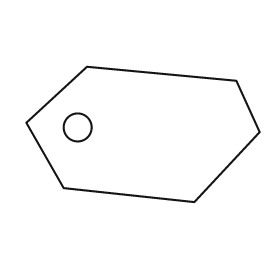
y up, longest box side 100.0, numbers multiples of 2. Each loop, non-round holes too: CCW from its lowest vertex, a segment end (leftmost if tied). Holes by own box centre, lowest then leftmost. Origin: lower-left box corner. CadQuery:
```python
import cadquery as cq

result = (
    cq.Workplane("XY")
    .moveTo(72.0, 0.0)
    .lineTo(100.0, 30.0)
    .lineTo(90.0, 52.0)
    .lineTo(26.0, 58.0)
    .lineTo(0.0, 34.0)
    .lineTo(16.0, 6.0)
    .close()
    .moveTo(22.0, 32.0)
    .circle(6.0)
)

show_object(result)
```